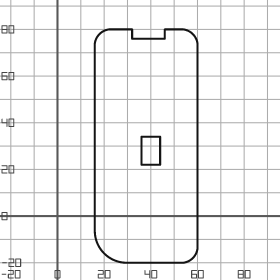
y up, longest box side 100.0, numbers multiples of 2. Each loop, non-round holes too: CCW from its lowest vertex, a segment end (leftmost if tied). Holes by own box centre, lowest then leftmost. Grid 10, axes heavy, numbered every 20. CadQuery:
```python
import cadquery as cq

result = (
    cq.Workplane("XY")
    .moveTo(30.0, -20.0)
    .lineTo(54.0, -20.0)
    .threePointArc((58.0, -18.0), (60.0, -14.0))
    .lineTo(60.0, 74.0)
    .threePointArc((58.0, 78.0), (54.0, 80.0))
    .lineTo(46.0, 80.0)
    .lineTo(46.0, 76.0)
    .lineTo(32.0, 76.0)
    .lineTo(32.0, 80.0)
    .lineTo(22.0, 80.0)
    .threePointArc((18.0, 78.0), (16.0, 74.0))
    .lineTo(16.0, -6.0)
    .threePointArc((20.0, -16.0), (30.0, -20.0))
    .close()
    .moveTo(36.0, 22.0)
    .lineTo(44.0, 22.0)
    .lineTo(44.0, 34.0)
    .lineTo(36.0, 34.0)
    .close()
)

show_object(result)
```